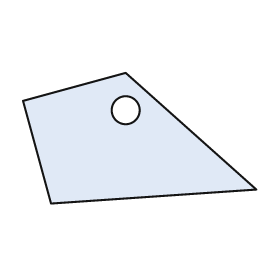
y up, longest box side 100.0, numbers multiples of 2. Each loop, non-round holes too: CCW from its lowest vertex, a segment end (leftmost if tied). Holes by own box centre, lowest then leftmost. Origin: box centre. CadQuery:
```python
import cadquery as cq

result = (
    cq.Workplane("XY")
    .moveTo(-38.0, -28.0)
    .lineTo(50.0, -22.0)
    .lineTo(-6.0, 28.0)
    .lineTo(-50.0, 16.0)
    .close()
    .moveTo(-6.0, 12.0)
    .circle(6.0)
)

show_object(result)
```